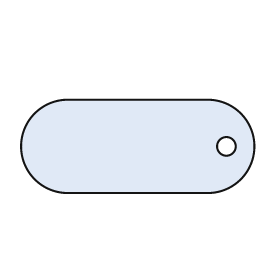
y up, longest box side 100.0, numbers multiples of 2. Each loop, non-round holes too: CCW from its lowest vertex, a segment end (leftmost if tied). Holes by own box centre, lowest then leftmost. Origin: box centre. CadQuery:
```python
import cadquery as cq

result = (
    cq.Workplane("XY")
    .moveTo(-30.0, -20.0)
    .lineTo(30.0, -20.0)
    .threePointArc((50.0, 0.0), (30.0, 20.0))
    .lineTo(-30.0, 20.0)
    .threePointArc((-50.0, 0.0), (-30.0, -20.0))
    .close()
    .moveTo(38.0, 0.0)
    .circle(4.0)
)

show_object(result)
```